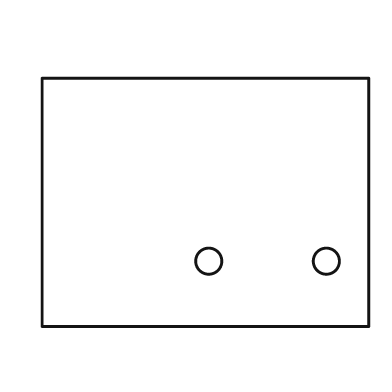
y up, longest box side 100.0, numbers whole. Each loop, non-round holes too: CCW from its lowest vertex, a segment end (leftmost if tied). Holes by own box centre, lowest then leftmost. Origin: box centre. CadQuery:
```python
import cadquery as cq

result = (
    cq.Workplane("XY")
    .moveTo(-50.0, -38.0)
    .lineTo(50.0, -38.0)
    .lineTo(50.0, 38.0)
    .lineTo(-50.0, 38.0)
    .close()
    .moveTo(1.0, -18.0)
    .circle(4.0)
    .moveTo(37.0, -18.0)
    .circle(4.0)
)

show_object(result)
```